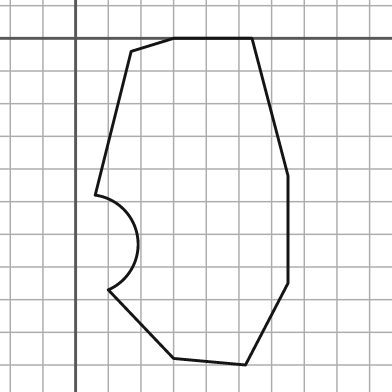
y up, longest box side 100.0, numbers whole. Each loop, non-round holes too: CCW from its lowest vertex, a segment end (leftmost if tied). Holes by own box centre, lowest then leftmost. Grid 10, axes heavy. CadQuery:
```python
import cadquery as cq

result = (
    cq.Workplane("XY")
    .moveTo(52.0, -100.0)
    .lineTo(65.0, -75.0)
    .lineTo(65.0, -42.0)
    .lineTo(54.0, 0.0)
    .lineTo(30.0, 0.0)
    .lineTo(17.0, -4.0)
    .lineTo(6.0, -48.0)
    .threePointArc((19.0, -61.0), (10.0, -77.0))
    .lineTo(30.0, -98.0)
    .close()
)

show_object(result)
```